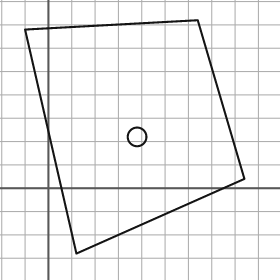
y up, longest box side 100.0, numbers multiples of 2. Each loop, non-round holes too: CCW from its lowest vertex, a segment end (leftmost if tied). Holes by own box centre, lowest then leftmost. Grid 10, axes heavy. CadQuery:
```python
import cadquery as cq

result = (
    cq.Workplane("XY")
    .moveTo(12.0, -28.0)
    .lineTo(84.0, 4.0)
    .lineTo(64.0, 72.0)
    .lineTo(-10.0, 68.0)
    .close()
    .moveTo(38.0, 22.0)
    .circle(4.0)
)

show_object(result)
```